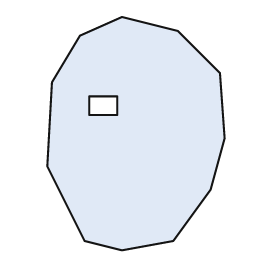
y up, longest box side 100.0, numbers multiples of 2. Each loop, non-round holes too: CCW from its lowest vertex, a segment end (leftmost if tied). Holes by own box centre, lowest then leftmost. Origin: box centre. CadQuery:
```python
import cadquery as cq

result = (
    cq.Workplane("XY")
    .moveTo(-6.0, -50.0)
    .lineTo(16.0, -46.0)
    .lineTo(32.0, -24.0)
    .lineTo(38.0, -2.0)
    .lineTo(36.0, 26.0)
    .lineTo(18.0, 44.0)
    .lineTo(-6.0, 50.0)
    .lineTo(-24.0, 42.0)
    .lineTo(-36.0, 22.0)
    .lineTo(-38.0, -14.0)
    .lineTo(-22.0, -46.0)
    .close()
    .moveTo(-20.0, 8.0)
    .lineTo(-8.0, 8.0)
    .lineTo(-8.0, 16.0)
    .lineTo(-20.0, 16.0)
    .close()
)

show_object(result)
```